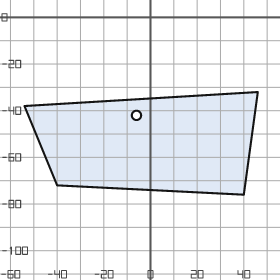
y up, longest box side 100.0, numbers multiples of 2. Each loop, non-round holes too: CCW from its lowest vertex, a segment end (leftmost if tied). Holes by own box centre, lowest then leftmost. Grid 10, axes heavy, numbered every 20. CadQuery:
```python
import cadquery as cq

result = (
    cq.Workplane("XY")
    .moveTo(40.0, -76.0)
    .lineTo(46.0, -32.0)
    .lineTo(-54.0, -38.0)
    .lineTo(-40.0, -72.0)
    .close()
    .moveTo(-6.0, -42.0)
    .circle(2.0)
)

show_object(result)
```